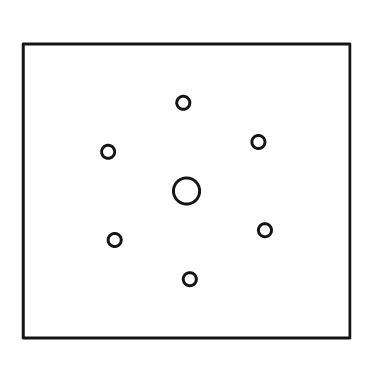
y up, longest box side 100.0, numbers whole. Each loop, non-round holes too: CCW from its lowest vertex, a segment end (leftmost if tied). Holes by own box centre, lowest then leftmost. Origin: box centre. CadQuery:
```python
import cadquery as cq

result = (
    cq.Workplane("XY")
    .moveTo(-50.0, -45.0)
    .lineTo(50.0, -45.0)
    .lineTo(50.0, 45.0)
    .lineTo(-50.0, 45.0)
    .close()
    .moveTo(1.0, -27.0)
    .circle(2.0)
    .moveTo(-22.0, -15.0)
    .circle(2.0)
    .moveTo(24.0, -12.0)
    .circle(2.0)
    .moveTo(0.0, 0.0)
    .circle(4.0)
    .moveTo(-24.0, 12.0)
    .circle(2.0)
    .moveTo(22.0, 15.0)
    .circle(2.0)
    .moveTo(-1.0, 27.0)
    .circle(2.0)
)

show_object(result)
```